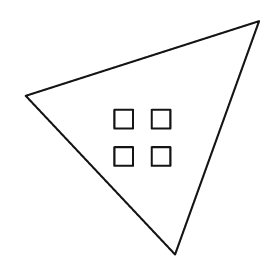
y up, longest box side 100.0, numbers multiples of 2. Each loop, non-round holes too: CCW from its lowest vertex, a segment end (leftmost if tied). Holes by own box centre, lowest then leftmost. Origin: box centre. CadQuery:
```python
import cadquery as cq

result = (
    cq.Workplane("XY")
    .moveTo(14.0, -50.0)
    .lineTo(50.0, 50.0)
    .lineTo(-50.0, 18.0)
    .close()
    .moveTo(-12.0, -12.0)
    .lineTo(-4.0, -12.0)
    .lineTo(-4.0, -4.0)
    .lineTo(-12.0, -4.0)
    .close()
    .moveTo(4.0, -12.0)
    .lineTo(12.0, -12.0)
    .lineTo(12.0, -4.0)
    .lineTo(4.0, -4.0)
    .close()
    .moveTo(-12.0, 4.0)
    .lineTo(-4.0, 4.0)
    .lineTo(-4.0, 12.0)
    .lineTo(-12.0, 12.0)
    .close()
    .moveTo(4.0, 4.0)
    .lineTo(12.0, 4.0)
    .lineTo(12.0, 12.0)
    .lineTo(4.0, 12.0)
    .close()
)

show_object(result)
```